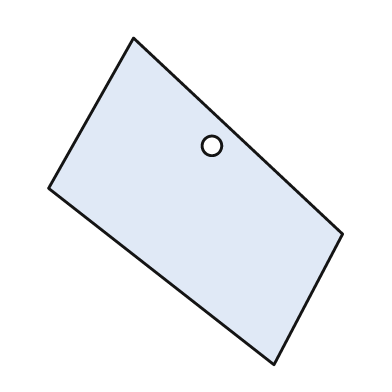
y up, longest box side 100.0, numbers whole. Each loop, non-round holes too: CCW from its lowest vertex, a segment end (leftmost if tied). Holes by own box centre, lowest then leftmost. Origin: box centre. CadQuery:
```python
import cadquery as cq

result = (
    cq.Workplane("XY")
    .moveTo(24.0, -50.0)
    .lineTo(45.0, -10.0)
    .lineTo(-19.0, 50.0)
    .lineTo(-45.0, 4.0)
    .close()
    .moveTo(5.0, 17.0)
    .circle(3.0)
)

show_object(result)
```